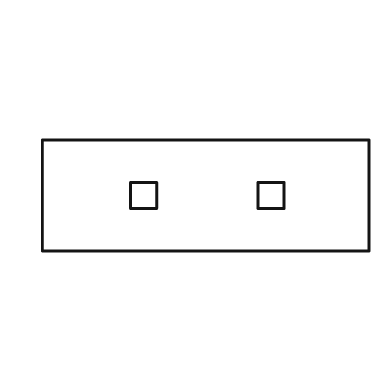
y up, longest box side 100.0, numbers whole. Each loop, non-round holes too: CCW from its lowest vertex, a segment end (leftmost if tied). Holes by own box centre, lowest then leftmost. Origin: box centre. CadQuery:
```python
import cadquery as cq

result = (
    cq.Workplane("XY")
    .moveTo(-50.0, -17.0)
    .lineTo(50.0, -17.0)
    .lineTo(50.0, 17.0)
    .lineTo(-50.0, 17.0)
    .close()
    .moveTo(-23.0, -4.0)
    .lineTo(-15.0, -4.0)
    .lineTo(-15.0, 4.0)
    .lineTo(-23.0, 4.0)
    .close()
    .moveTo(16.0, -4.0)
    .lineTo(24.0, -4.0)
    .lineTo(24.0, 4.0)
    .lineTo(16.0, 4.0)
    .close()
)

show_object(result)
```